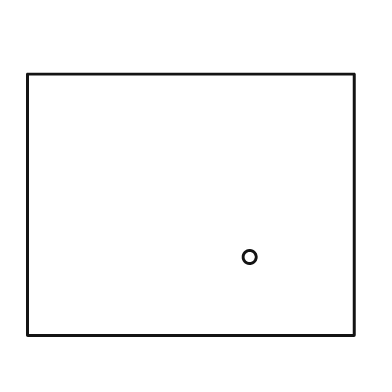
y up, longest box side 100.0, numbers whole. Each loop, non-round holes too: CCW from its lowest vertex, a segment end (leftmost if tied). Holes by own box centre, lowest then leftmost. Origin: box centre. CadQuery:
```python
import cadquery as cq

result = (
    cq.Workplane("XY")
    .moveTo(-50.0, -40.0)
    .lineTo(50.0, -40.0)
    .lineTo(50.0, 40.0)
    .lineTo(-50.0, 40.0)
    .close()
    .moveTo(18.0, -16.0)
    .circle(2.0)
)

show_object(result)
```